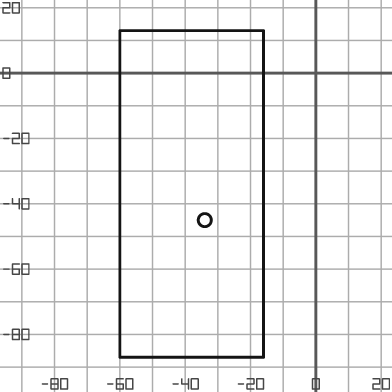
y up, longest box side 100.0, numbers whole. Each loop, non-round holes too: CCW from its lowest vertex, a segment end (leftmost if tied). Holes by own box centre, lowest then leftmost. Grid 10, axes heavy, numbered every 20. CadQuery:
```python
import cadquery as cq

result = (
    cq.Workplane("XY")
    .moveTo(-60.0, -87.0)
    .lineTo(-16.0, -87.0)
    .lineTo(-16.0, 13.0)
    .lineTo(-60.0, 13.0)
    .close()
    .moveTo(-34.0, -45.0)
    .circle(2.0)
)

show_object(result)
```